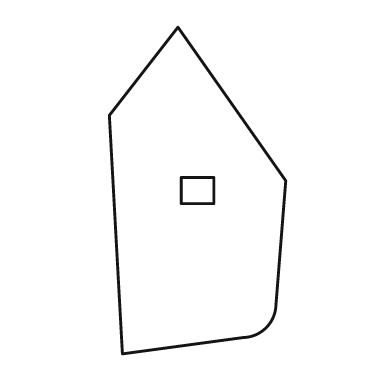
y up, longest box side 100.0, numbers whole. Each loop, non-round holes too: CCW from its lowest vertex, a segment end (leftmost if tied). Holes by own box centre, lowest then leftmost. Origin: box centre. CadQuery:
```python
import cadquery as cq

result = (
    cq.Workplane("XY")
    .moveTo(-23.0, -50.0)
    .lineTo(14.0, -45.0)
    .threePointArc((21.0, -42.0), (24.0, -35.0))
    .lineTo(27.0, 3.0)
    .lineTo(-6.0, 50.0)
    .lineTo(-27.0, 23.0)
    .close()
    .moveTo(-5.0, -4.0)
    .lineTo(5.0, -4.0)
    .lineTo(5.0, 4.0)
    .lineTo(-5.0, 4.0)
    .close()
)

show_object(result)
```